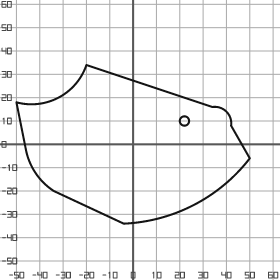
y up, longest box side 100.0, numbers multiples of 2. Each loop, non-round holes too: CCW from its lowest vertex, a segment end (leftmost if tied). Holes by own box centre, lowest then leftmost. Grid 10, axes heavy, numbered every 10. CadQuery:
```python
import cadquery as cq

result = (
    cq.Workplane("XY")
    .moveTo(-4.0, -34.0)
    .threePointArc((26.0, -26.0), (50.0, -6.0))
    .lineTo(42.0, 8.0)
    .threePointArc((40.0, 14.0), (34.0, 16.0))
    .lineTo(-20.0, 34.0)
    .threePointArc((-32.0, 20.0), (-50.0, 18.0))
    .lineTo(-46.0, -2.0)
    .threePointArc((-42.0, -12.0), (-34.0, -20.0))
    .close()
    .moveTo(22.0, 10.0)
    .circle(2.0)
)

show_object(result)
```